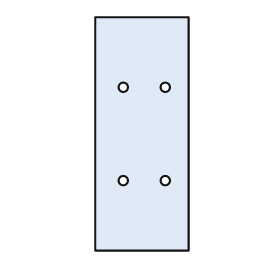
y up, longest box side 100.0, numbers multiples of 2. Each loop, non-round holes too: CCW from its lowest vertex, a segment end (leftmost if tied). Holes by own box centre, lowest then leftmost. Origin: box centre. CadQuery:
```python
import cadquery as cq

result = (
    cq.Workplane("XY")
    .moveTo(-20.0, -50.0)
    .lineTo(20.0, -50.0)
    .lineTo(20.0, 50.0)
    .lineTo(-20.0, 50.0)
    .close()
    .moveTo(-8.0, -20.0)
    .circle(2.0)
    .moveTo(10.0, -20.0)
    .circle(2.0)
    .moveTo(-8.0, 20.0)
    .circle(2.0)
    .moveTo(10.0, 20.0)
    .circle(2.0)
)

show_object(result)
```